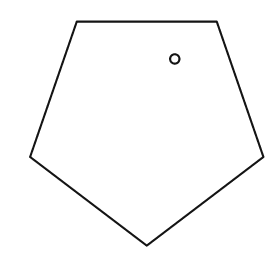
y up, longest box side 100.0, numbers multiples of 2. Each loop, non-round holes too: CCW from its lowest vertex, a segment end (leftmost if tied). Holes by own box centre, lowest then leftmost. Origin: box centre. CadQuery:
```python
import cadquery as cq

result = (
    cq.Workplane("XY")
    .moveTo(0.0, -48.0)
    .lineTo(50.0, -10.0)
    .lineTo(30.0, 48.0)
    .lineTo(-30.0, 48.0)
    .lineTo(-50.0, -10.0)
    .close()
    .moveTo(12.0, 32.0)
    .circle(2.0)
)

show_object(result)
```